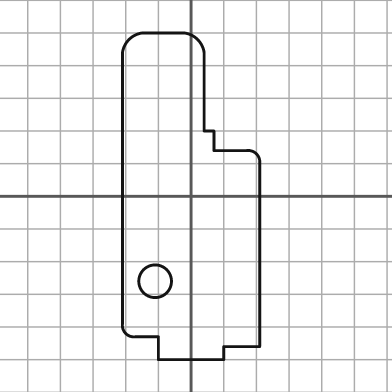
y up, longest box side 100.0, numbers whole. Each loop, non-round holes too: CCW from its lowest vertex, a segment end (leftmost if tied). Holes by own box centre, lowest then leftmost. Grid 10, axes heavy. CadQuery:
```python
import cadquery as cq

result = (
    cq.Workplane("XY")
    .moveTo(-10.0, -50.0)
    .lineTo(10.0, -50.0)
    .lineTo(10.0, -46.0)
    .lineTo(21.0, -46.0)
    .lineTo(21.0, 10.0)
    .threePointArc((20.0, 13.0), (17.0, 14.0))
    .lineTo(7.0, 14.0)
    .lineTo(7.0, 20.0)
    .lineTo(4.0, 20.0)
    .lineTo(4.0, 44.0)
    .threePointArc((2.0, 48.0), (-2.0, 50.0))
    .lineTo(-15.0, 50.0)
    .threePointArc((-19.0, 48.0), (-21.0, 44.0))
    .lineTo(-21.0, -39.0)
    .threePointArc((-20.0, -42.0), (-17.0, -43.0))
    .lineTo(-10.0, -43.0)
    .close()
    .moveTo(-11.0, -26.0)
    .circle(5.0)
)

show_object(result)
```